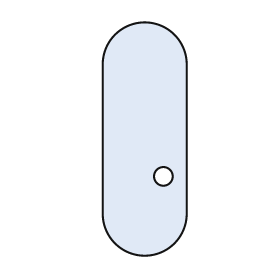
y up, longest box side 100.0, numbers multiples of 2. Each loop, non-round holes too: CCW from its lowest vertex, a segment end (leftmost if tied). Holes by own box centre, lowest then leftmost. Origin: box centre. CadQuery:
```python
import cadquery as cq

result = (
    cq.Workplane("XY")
    .moveTo(-18.0, -32.0)
    .threePointArc((0.0, -50.0), (18.0, -32.0))
    .lineTo(18.0, 32.0)
    .threePointArc((0.0, 50.0), (-18.0, 32.0))
    .close()
    .moveTo(8.0, -16.0)
    .circle(4.0)
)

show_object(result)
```